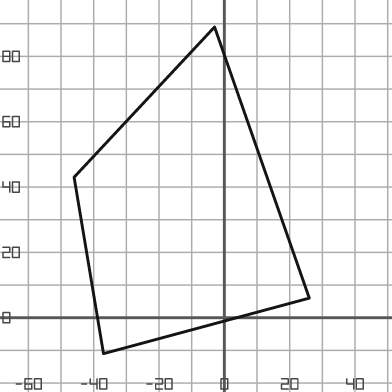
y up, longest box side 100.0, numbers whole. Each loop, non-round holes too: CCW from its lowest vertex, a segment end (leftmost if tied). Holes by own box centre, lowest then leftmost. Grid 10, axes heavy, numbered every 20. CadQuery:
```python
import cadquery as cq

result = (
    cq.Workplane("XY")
    .moveTo(-37.0, -11.0)
    .lineTo(26.0, 6.0)
    .lineTo(-3.0, 89.0)
    .lineTo(-46.0, 43.0)
    .close()
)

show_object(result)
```